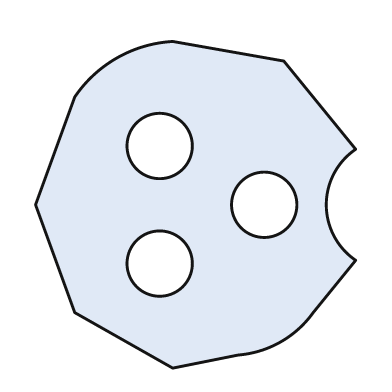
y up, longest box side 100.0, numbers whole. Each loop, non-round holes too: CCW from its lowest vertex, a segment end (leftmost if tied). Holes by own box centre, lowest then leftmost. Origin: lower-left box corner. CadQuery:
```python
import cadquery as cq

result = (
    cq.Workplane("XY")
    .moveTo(42.0, 0.0)
    .lineTo(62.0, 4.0)
    .threePointArc((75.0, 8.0), (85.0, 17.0))
    .lineTo(98.0, 33.0)
    .threePointArc((89.0, 50.0), (98.0, 67.0))
    .lineTo(76.0, 94.0)
    .lineTo(42.0, 100.0)
    .threePointArc((25.0, 95.0), (12.0, 83.0))
    .lineTo(0.0, 50.0)
    .lineTo(12.0, 17.0)
    .close()
    .moveTo(38.0, 32.0)
    .circle(10.0)
    .moveTo(70.0, 50.0)
    .circle(10.0)
    .moveTo(38.0, 68.0)
    .circle(10.0)
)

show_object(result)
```